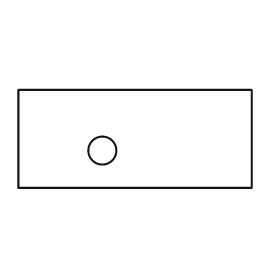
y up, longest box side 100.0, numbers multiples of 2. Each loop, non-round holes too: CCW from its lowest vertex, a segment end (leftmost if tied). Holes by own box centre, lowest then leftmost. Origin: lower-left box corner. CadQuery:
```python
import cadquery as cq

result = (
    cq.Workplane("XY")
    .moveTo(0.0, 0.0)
    .lineTo(100.0, 0.0)
    .lineTo(100.0, 42.0)
    .lineTo(0.0, 42.0)
    .close()
    .moveTo(36.0, 16.0)
    .circle(6.0)
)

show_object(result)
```